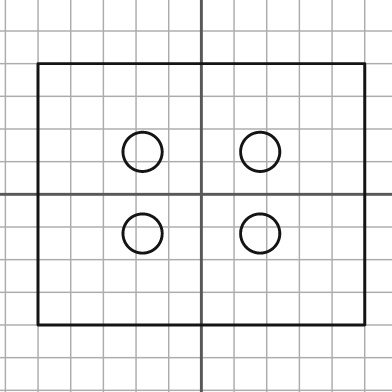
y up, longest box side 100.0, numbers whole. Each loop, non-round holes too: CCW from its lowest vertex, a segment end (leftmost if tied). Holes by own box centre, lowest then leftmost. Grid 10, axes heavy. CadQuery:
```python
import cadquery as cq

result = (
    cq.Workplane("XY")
    .moveTo(-50.0, -40.0)
    .lineTo(50.0, -40.0)
    .lineTo(50.0, 40.0)
    .lineTo(-50.0, 40.0)
    .close()
    .moveTo(-18.0, -12.0)
    .circle(6.0)
    .moveTo(18.0, -12.0)
    .circle(6.0)
    .moveTo(-18.0, 13.0)
    .circle(6.0)
    .moveTo(18.0, 13.0)
    .circle(6.0)
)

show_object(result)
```